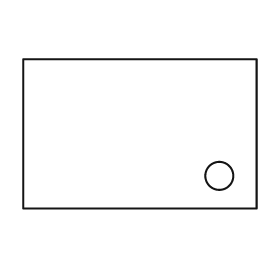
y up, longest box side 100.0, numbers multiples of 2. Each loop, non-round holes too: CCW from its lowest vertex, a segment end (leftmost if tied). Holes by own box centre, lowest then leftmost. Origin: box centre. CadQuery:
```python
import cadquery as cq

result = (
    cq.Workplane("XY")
    .moveTo(-50.0, -32.0)
    .lineTo(50.0, -32.0)
    .lineTo(50.0, 32.0)
    .lineTo(-50.0, 32.0)
    .close()
    .moveTo(34.0, -18.0)
    .circle(6.0)
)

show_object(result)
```